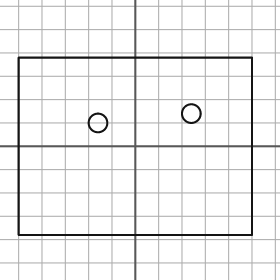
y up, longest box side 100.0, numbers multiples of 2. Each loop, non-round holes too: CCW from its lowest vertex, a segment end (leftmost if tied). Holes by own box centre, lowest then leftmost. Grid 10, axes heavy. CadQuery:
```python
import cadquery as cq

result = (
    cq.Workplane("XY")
    .moveTo(-50.0, -38.0)
    .lineTo(50.0, -38.0)
    .lineTo(50.0, 38.0)
    .lineTo(-50.0, 38.0)
    .close()
    .moveTo(-16.0, 10.0)
    .circle(4.0)
    .moveTo(24.0, 14.0)
    .circle(4.0)
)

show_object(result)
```